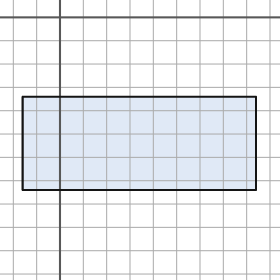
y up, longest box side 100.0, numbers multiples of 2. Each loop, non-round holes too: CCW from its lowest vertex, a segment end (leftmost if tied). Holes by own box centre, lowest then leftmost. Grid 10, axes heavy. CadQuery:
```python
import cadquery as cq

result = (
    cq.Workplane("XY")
    .moveTo(-16.0, -74.0)
    .lineTo(84.0, -74.0)
    .lineTo(84.0, -34.0)
    .lineTo(-16.0, -34.0)
    .close()
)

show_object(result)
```